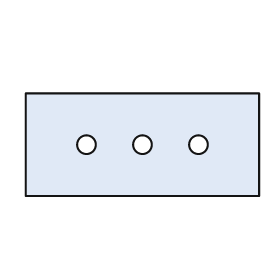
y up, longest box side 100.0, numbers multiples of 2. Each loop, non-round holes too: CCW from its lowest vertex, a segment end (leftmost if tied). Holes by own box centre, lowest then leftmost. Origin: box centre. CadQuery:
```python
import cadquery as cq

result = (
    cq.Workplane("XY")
    .moveTo(-50.0, -22.0)
    .lineTo(50.0, -22.0)
    .lineTo(50.0, 22.0)
    .lineTo(-50.0, 22.0)
    .close()
    .moveTo(-24.0, 0.0)
    .circle(4.0)
    .moveTo(0.0, 0.0)
    .circle(4.0)
    .moveTo(24.0, 0.0)
    .circle(4.0)
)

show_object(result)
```